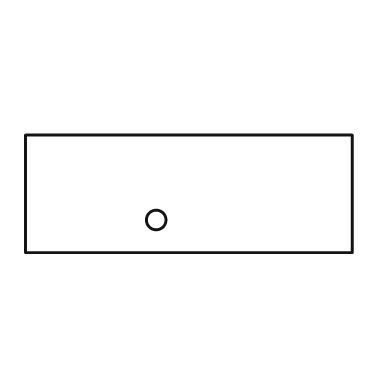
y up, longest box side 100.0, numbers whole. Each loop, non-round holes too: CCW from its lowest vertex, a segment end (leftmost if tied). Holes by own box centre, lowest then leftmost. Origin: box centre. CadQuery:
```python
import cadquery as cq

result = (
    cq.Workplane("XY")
    .moveTo(-50.0, -18.0)
    .lineTo(50.0, -18.0)
    .lineTo(50.0, 18.0)
    .lineTo(-50.0, 18.0)
    .close()
    .moveTo(-10.0, -8.0)
    .circle(3.0)
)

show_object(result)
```